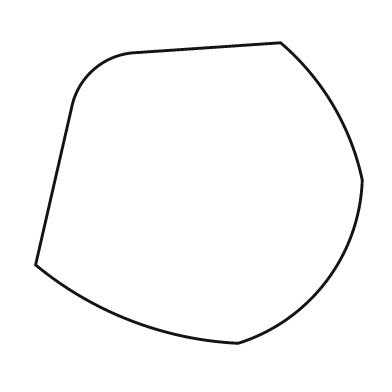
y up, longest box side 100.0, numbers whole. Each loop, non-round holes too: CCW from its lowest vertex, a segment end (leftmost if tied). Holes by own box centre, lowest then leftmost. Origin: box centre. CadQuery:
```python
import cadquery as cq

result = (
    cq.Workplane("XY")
    .moveTo(12.0, -46.0)
    .threePointArc((39.0, -27.0), (50.0, 4.0))
    .threePointArc((41.0, 27.0), (25.0, 46.0))
    .lineTo(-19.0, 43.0)
    .threePointArc((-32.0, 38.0), (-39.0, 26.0))
    .lineTo(-50.0, -22.0)
    .threePointArc((-21.0, -39.0), (12.0, -46.0))
    .close()
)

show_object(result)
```